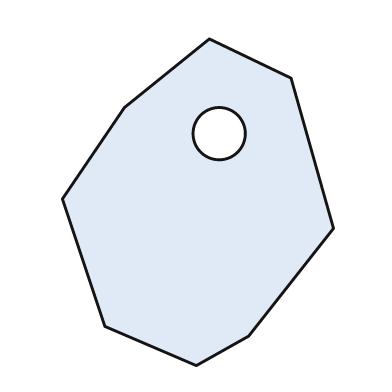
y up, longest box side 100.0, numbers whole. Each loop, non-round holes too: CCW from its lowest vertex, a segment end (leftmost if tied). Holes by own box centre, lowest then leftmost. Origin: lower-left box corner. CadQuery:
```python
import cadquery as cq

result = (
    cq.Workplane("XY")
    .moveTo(41.0, 0.0)
    .lineTo(57.0, 9.0)
    .lineTo(83.0, 42.0)
    .lineTo(70.0, 88.0)
    .lineTo(45.0, 100.0)
    .lineTo(19.0, 79.0)
    .lineTo(0.0, 51.0)
    .lineTo(13.0, 12.0)
    .close()
    .moveTo(48.0, 71.0)
    .circle(8.0)
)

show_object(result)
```